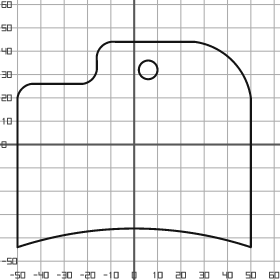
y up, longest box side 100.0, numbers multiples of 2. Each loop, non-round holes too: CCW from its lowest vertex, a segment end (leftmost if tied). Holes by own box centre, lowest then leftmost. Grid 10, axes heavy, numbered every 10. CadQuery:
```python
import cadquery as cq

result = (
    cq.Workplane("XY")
    .moveTo(-50.0, -44.0)
    .threePointArc((0.0, -36.0), (50.0, -44.0))
    .lineTo(50.0, 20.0)
    .threePointArc((42.0, 36.0), (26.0, 44.0))
    .lineTo(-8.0, 44.0)
    .threePointArc((-14.0, 42.0), (-16.0, 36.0))
    .lineTo(-16.0, 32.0)
    .threePointArc((-18.0, 28.0), (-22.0, 26.0))
    .lineTo(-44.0, 26.0)
    .threePointArc((-48.0, 24.0), (-50.0, 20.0))
    .close()
    .moveTo(6.0, 32.0)
    .circle(4.0)
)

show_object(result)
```